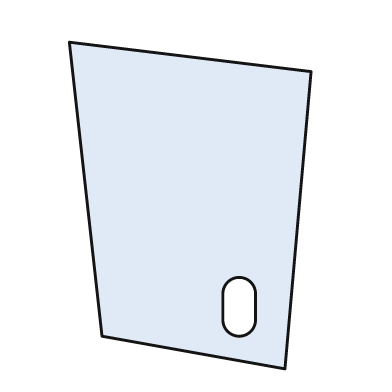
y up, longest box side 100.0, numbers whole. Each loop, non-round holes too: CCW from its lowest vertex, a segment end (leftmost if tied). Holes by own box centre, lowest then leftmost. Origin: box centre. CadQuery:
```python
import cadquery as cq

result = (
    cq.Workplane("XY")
    .moveTo(29.0, -50.0)
    .lineTo(37.0, 41.0)
    .lineTo(-37.0, 50.0)
    .lineTo(-27.0, -40.0)
    .close()
    .moveTo(10.0, -35.0)
    .threePointArc((15.0, -40.0), (20.0, -35.0))
    .lineTo(20.0, -27.0)
    .threePointArc((15.0, -22.0), (10.0, -27.0))
    .close()
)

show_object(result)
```